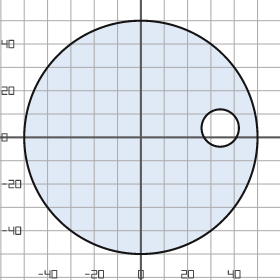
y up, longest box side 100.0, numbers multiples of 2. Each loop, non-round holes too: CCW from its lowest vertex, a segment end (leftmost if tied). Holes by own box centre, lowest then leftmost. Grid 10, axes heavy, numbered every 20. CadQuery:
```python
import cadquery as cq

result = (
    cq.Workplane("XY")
    .moveTo(0.0, 0.0)
    .circle(50.0)
    .moveTo(34.0, 4.0)
    .circle(8.0)
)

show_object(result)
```